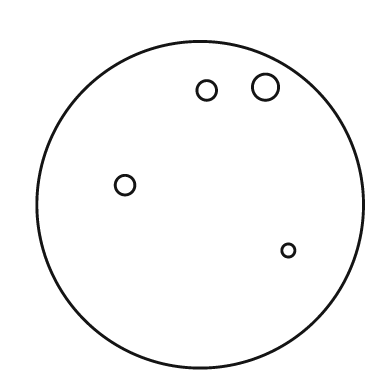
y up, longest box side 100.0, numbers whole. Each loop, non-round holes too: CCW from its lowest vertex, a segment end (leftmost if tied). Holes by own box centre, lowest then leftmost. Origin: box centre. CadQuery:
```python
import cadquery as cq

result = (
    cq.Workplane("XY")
    .moveTo(0.0, 0.0)
    .circle(50.0)
    .moveTo(27.0, -14.0)
    .circle(2.0)
    .moveTo(-23.0, 6.0)
    .circle(3.0)
    .moveTo(2.0, 35.0)
    .circle(3.0)
    .moveTo(20.0, 36.0)
    .circle(4.0)
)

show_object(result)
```